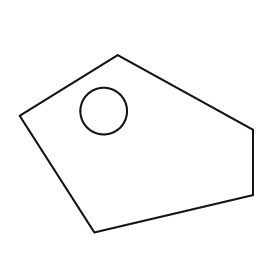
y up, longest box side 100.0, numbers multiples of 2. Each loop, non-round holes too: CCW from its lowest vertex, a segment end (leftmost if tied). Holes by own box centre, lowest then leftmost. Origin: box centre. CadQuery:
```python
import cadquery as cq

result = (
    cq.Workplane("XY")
    .moveTo(-18.0, -38.0)
    .lineTo(50.0, -22.0)
    .lineTo(50.0, 6.0)
    .lineTo(-8.0, 38.0)
    .lineTo(-50.0, 12.0)
    .close()
    .moveTo(-14.0, 14.0)
    .circle(10.0)
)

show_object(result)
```